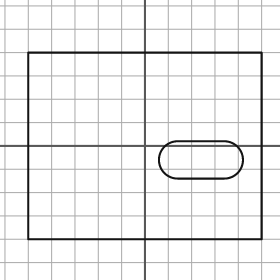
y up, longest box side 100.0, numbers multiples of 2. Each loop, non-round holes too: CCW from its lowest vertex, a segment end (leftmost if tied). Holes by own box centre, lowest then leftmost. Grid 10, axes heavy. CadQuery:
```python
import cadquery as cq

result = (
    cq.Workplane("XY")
    .moveTo(-50.0, -40.0)
    .lineTo(50.0, -40.0)
    .lineTo(50.0, 40.0)
    .lineTo(-50.0, 40.0)
    .close()
    .moveTo(14.0, -14.0)
    .lineTo(34.0, -14.0)
    .threePointArc((42.0, -6.0), (34.0, 2.0))
    .lineTo(14.0, 2.0)
    .threePointArc((6.0, -6.0), (14.0, -14.0))
    .close()
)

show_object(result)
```